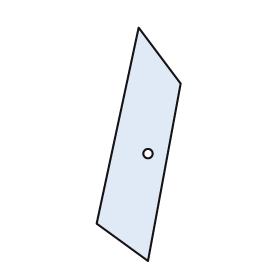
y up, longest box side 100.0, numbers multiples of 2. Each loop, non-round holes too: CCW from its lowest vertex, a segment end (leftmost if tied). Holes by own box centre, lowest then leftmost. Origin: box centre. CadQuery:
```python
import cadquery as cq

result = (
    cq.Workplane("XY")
    .moveTo(4.0, -50.0)
    .lineTo(18.0, 26.0)
    .lineTo(0.0, 50.0)
    .lineTo(-18.0, -34.0)
    .close()
    .moveTo(4.0, -4.0)
    .circle(2.0)
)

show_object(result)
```